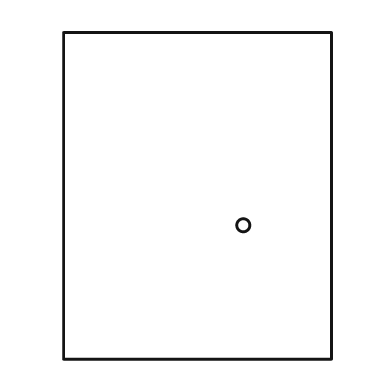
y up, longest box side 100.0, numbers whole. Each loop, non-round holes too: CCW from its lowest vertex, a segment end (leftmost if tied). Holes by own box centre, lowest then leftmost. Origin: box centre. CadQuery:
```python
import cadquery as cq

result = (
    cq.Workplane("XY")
    .moveTo(-41.0, -50.0)
    .lineTo(41.0, -50.0)
    .lineTo(41.0, 50.0)
    .lineTo(-41.0, 50.0)
    .close()
    .moveTo(14.0, -9.0)
    .circle(2.0)
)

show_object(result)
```